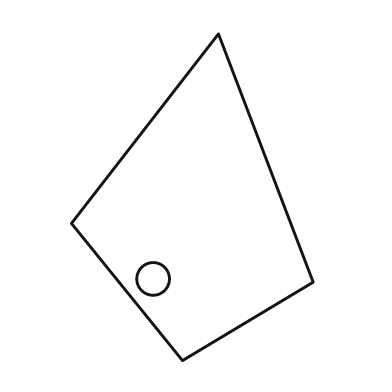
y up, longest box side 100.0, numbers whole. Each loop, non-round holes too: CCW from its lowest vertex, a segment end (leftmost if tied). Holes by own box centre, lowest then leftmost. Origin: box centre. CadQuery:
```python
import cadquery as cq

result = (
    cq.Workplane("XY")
    .moveTo(-3.0, -50.0)
    .lineTo(37.0, -26.0)
    .lineTo(8.0, 50.0)
    .lineTo(-37.0, -8.0)
    .close()
    .moveTo(-12.0, -25.0)
    .circle(5.0)
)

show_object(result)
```